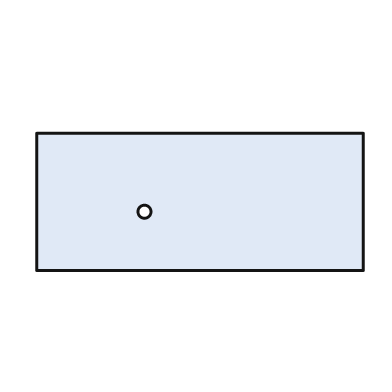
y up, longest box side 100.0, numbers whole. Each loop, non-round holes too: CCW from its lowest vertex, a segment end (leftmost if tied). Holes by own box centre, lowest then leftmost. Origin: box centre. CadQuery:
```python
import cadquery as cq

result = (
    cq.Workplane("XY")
    .moveTo(-50.0, -21.0)
    .lineTo(50.0, -21.0)
    .lineTo(50.0, 21.0)
    .lineTo(-50.0, 21.0)
    .close()
    .moveTo(-17.0, -3.0)
    .circle(2.0)
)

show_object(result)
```